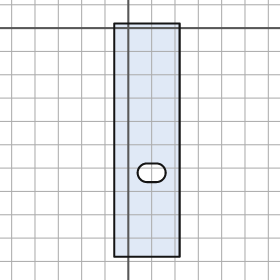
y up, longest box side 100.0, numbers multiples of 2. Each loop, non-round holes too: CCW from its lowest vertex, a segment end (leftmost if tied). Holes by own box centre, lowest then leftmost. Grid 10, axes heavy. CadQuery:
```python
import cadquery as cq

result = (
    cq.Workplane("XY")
    .moveTo(-6.0, -98.0)
    .lineTo(22.0, -98.0)
    .lineTo(22.0, 2.0)
    .lineTo(-6.0, 2.0)
    .close()
    .moveTo(8.0, -66.0)
    .lineTo(12.0, -66.0)
    .threePointArc((16.0, -62.0), (12.0, -58.0))
    .lineTo(8.0, -58.0)
    .threePointArc((4.0, -62.0), (8.0, -66.0))
    .close()
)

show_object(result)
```